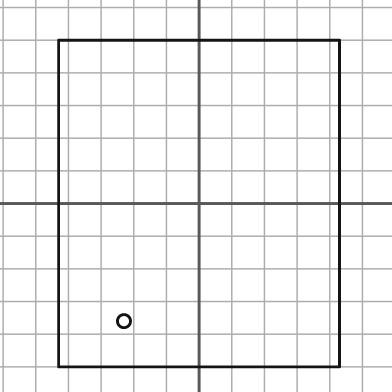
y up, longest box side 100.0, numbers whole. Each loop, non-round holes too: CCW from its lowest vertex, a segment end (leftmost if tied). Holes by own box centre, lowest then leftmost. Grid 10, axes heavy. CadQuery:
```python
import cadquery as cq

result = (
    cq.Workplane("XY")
    .moveTo(-43.0, -50.0)
    .lineTo(43.0, -50.0)
    .lineTo(43.0, 50.0)
    .lineTo(-43.0, 50.0)
    .close()
    .moveTo(-23.0, -36.0)
    .circle(2.0)
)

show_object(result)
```